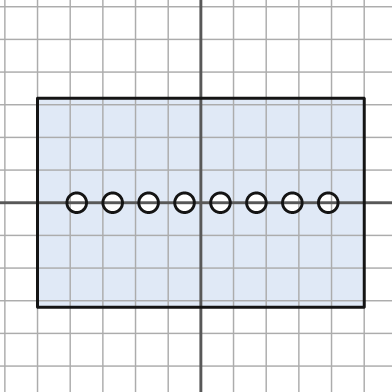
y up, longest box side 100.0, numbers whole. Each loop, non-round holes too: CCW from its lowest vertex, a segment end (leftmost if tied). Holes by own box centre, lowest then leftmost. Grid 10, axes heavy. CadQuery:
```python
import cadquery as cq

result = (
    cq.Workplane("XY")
    .moveTo(-50.0, -32.0)
    .lineTo(50.0, -32.0)
    .lineTo(50.0, 32.0)
    .lineTo(-50.0, 32.0)
    .close()
    .moveTo(-38.0, 0.0)
    .circle(3.0)
    .moveTo(-27.0, 0.0)
    .circle(3.0)
    .moveTo(-16.0, 0.0)
    .circle(3.0)
    .moveTo(-5.0, 0.0)
    .circle(3.0)
    .moveTo(6.0, 0.0)
    .circle(3.0)
    .moveTo(17.0, 0.0)
    .circle(3.0)
    .moveTo(28.0, 0.0)
    .circle(3.0)
    .moveTo(39.0, 0.0)
    .circle(3.0)
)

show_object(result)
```